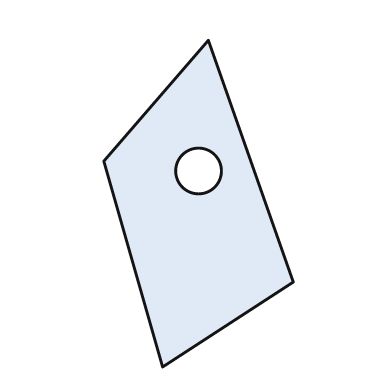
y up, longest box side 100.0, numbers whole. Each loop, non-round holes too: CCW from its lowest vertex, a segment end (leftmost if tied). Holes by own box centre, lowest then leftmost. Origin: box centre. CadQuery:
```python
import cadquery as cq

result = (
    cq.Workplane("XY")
    .moveTo(-11.0, -50.0)
    .lineTo(29.0, -24.0)
    .lineTo(3.0, 50.0)
    .lineTo(-29.0, 13.0)
    .close()
    .moveTo(0.0, 10.0)
    .circle(7.0)
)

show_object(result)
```